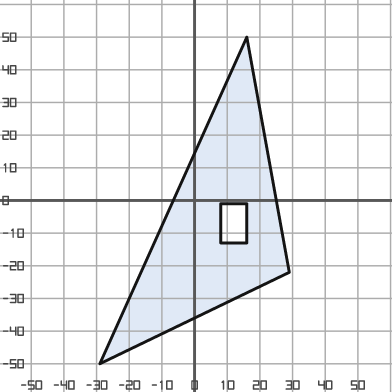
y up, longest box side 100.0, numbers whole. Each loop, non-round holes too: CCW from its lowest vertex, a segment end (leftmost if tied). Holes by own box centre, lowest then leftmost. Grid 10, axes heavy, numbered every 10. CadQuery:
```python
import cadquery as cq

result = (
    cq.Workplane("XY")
    .moveTo(-29.0, -50.0)
    .lineTo(29.0, -22.0)
    .lineTo(16.0, 50.0)
    .close()
    .moveTo(8.0, -13.0)
    .lineTo(16.0, -13.0)
    .lineTo(16.0, -1.0)
    .lineTo(8.0, -1.0)
    .close()
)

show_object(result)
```